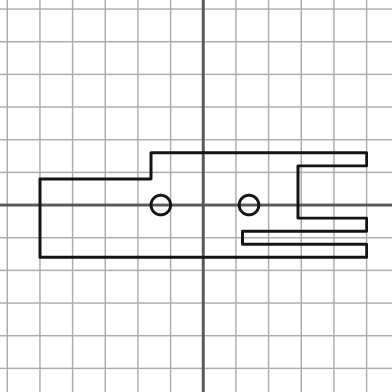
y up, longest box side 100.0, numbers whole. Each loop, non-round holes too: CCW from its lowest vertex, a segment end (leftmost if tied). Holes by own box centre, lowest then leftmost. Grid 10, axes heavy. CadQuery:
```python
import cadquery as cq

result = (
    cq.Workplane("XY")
    .moveTo(-50.0, -16.0)
    .lineTo(50.0, -16.0)
    .lineTo(50.0, -12.0)
    .lineTo(12.0, -12.0)
    .lineTo(12.0, -8.0)
    .lineTo(50.0, -8.0)
    .lineTo(50.0, -4.0)
    .lineTo(29.0, -4.0)
    .lineTo(29.0, 12.0)
    .lineTo(50.0, 12.0)
    .lineTo(50.0, 16.0)
    .lineTo(-16.0, 16.0)
    .lineTo(-16.0, 8.0)
    .lineTo(-50.0, 8.0)
    .close()
    .moveTo(-13.0, 0.0)
    .circle(3.0)
    .moveTo(14.0, 0.0)
    .circle(3.0)
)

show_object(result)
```